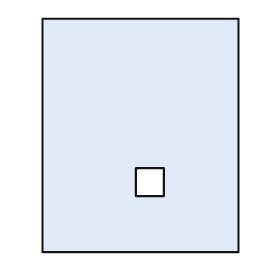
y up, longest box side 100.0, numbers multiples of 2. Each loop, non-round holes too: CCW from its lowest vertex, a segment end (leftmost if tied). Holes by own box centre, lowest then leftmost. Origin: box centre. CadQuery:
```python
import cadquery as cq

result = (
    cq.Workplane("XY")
    .moveTo(-42.0, -50.0)
    .lineTo(42.0, -50.0)
    .lineTo(42.0, 50.0)
    .lineTo(-42.0, 50.0)
    .close()
    .moveTo(-2.0, -26.0)
    .lineTo(10.0, -26.0)
    .lineTo(10.0, -14.0)
    .lineTo(-2.0, -14.0)
    .close()
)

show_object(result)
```